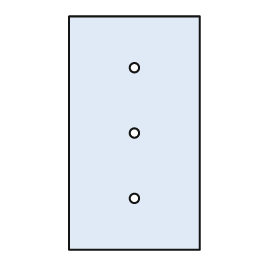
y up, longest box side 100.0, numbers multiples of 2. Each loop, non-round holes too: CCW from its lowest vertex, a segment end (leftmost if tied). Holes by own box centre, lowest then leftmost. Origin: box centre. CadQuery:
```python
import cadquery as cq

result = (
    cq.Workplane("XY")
    .moveTo(-28.0, -50.0)
    .lineTo(28.0, -50.0)
    .lineTo(28.0, 50.0)
    .lineTo(-28.0, 50.0)
    .close()
    .moveTo(0.0, -28.0)
    .circle(2.0)
    .moveTo(0.0, 0.0)
    .circle(2.0)
    .moveTo(0.0, 28.0)
    .circle(2.0)
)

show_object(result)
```